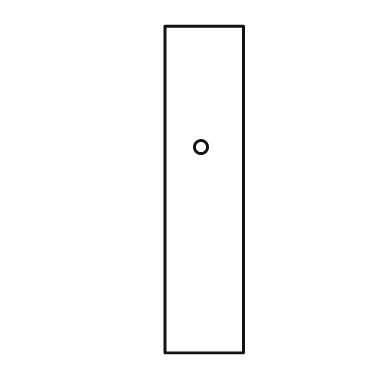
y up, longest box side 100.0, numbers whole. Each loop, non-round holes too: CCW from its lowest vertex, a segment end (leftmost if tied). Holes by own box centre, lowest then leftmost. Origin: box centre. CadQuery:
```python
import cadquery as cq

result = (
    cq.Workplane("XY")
    .moveTo(-12.0, -50.0)
    .lineTo(12.0, -50.0)
    .lineTo(12.0, 50.0)
    .lineTo(-12.0, 50.0)
    .close()
    .moveTo(-1.0, 13.0)
    .circle(2.0)
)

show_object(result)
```